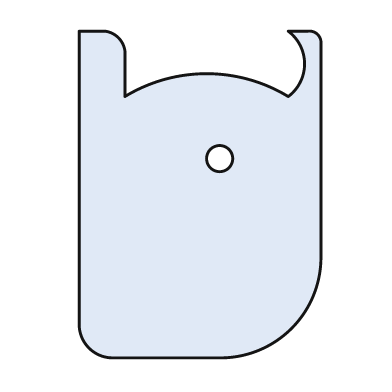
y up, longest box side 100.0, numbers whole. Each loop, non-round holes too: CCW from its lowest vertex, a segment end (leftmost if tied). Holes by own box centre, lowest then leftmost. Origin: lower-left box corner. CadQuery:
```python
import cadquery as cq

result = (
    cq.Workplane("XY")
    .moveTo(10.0, 0.0)
    .lineTo(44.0, 0.0)
    .threePointArc((65.0, 9.0), (74.0, 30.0))
    .lineTo(74.0, 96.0)
    .threePointArc((73.0, 99.0), (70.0, 100.0))
    .lineTo(64.0, 100.0)
    .threePointArc((69.0, 90.0), (64.0, 80.0))
    .threePointArc((39.0, 87.0), (14.0, 80.0))
    .lineTo(14.0, 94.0)
    .threePointArc((12.0, 98.0), (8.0, 100.0))
    .lineTo(0.0, 100.0)
    .lineTo(0.0, 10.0)
    .threePointArc((3.0, 3.0), (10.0, 0.0))
    .close()
    .moveTo(43.0, 61.0)
    .circle(4.0)
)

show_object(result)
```